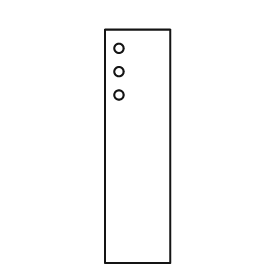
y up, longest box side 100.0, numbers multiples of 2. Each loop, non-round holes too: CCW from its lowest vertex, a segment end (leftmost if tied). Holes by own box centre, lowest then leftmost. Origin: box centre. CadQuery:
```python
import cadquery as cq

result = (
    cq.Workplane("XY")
    .moveTo(-14.0, -50.0)
    .lineTo(14.0, -50.0)
    .lineTo(14.0, 50.0)
    .lineTo(-14.0, 50.0)
    .close()
    .moveTo(-8.0, 22.0)
    .circle(2.0)
    .moveTo(-8.0, 32.0)
    .circle(2.0)
    .moveTo(-8.0, 42.0)
    .circle(2.0)
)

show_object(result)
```